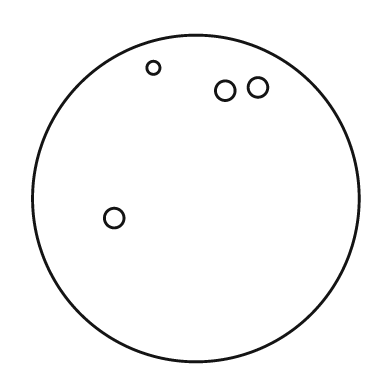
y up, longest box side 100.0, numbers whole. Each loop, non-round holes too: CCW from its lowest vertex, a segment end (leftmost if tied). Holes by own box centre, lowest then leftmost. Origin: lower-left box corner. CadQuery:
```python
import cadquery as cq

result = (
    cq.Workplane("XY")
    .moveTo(50.0, 50.0)
    .circle(50.0)
    .moveTo(25.0, 44.0)
    .circle(3.0)
    .moveTo(59.0, 83.0)
    .circle(3.0)
    .moveTo(69.0, 84.0)
    .circle(3.0)
    .moveTo(37.0, 90.0)
    .circle(2.0)
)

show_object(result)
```